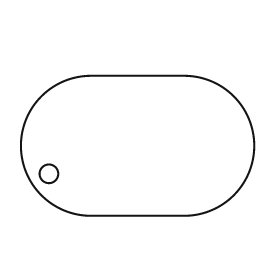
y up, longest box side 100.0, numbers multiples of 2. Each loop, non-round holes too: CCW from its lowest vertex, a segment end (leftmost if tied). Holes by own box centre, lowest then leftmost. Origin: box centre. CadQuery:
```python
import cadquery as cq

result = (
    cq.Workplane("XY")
    .moveTo(-20.0, -30.0)
    .lineTo(20.0, -30.0)
    .threePointArc((50.0, 0.0), (20.0, 30.0))
    .lineTo(-20.0, 30.0)
    .threePointArc((-50.0, 0.0), (-20.0, -30.0))
    .close()
    .moveTo(-38.0, -12.0)
    .circle(4.0)
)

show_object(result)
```